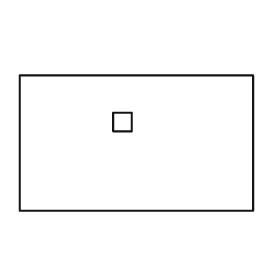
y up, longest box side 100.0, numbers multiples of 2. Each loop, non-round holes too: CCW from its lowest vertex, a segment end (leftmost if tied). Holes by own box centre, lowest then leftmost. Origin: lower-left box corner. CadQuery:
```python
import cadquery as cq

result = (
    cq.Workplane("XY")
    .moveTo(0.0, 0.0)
    .lineTo(100.0, 0.0)
    .lineTo(100.0, 58.0)
    .lineTo(0.0, 58.0)
    .close()
    .moveTo(40.0, 34.0)
    .lineTo(48.0, 34.0)
    .lineTo(48.0, 42.0)
    .lineTo(40.0, 42.0)
    .close()
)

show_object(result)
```